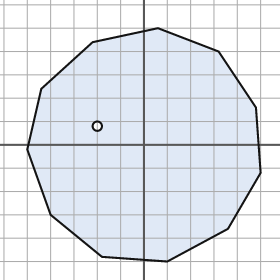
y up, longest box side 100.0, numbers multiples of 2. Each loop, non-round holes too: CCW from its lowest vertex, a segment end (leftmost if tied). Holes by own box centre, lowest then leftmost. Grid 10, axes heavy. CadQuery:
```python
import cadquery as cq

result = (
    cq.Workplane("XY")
    .moveTo(10.0, -50.0)
    .lineTo(36.0, -36.0)
    .lineTo(50.0, -12.0)
    .lineTo(48.0, 16.0)
    .lineTo(32.0, 40.0)
    .lineTo(6.0, 50.0)
    .lineTo(-22.0, 44.0)
    .lineTo(-44.0, 24.0)
    .lineTo(-50.0, -2.0)
    .lineTo(-40.0, -30.0)
    .lineTo(-18.0, -48.0)
    .close()
    .moveTo(-20.0, 8.0)
    .circle(2.0)
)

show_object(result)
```